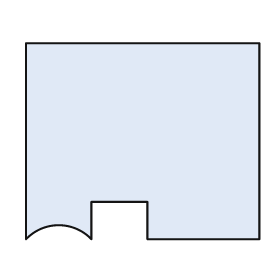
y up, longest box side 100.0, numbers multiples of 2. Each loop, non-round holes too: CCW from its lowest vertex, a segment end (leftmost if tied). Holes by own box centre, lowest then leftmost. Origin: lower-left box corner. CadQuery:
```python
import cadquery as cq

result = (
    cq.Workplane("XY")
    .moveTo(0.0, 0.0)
    .threePointArc((14.0, 6.0), (28.0, 0.0))
    .lineTo(28.0, 16.0)
    .lineTo(52.0, 16.0)
    .lineTo(52.0, 0.0)
    .lineTo(100.0, 0.0)
    .lineTo(100.0, 84.0)
    .lineTo(0.0, 84.0)
    .close()
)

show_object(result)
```